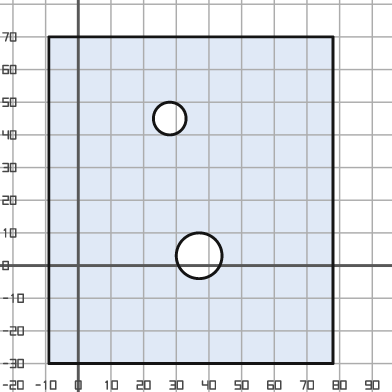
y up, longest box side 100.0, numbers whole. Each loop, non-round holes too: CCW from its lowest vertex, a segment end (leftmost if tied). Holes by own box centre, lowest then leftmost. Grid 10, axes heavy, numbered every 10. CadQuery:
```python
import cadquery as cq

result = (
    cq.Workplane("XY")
    .moveTo(-9.0, -30.0)
    .lineTo(78.0, -30.0)
    .lineTo(78.0, 70.0)
    .lineTo(-9.0, 70.0)
    .close()
    .moveTo(37.0, 3.0)
    .circle(7.0)
    .moveTo(28.0, 45.0)
    .circle(5.0)
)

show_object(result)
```